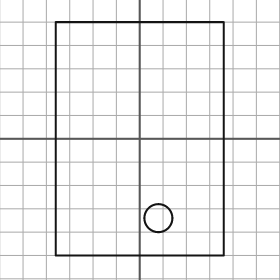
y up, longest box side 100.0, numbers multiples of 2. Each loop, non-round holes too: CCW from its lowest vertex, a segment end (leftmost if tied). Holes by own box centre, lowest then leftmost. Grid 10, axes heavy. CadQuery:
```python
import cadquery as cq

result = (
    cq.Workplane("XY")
    .moveTo(-36.0, -50.0)
    .lineTo(36.0, -50.0)
    .lineTo(36.0, 50.0)
    .lineTo(-36.0, 50.0)
    .close()
    .moveTo(8.0, -34.0)
    .circle(6.0)
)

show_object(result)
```